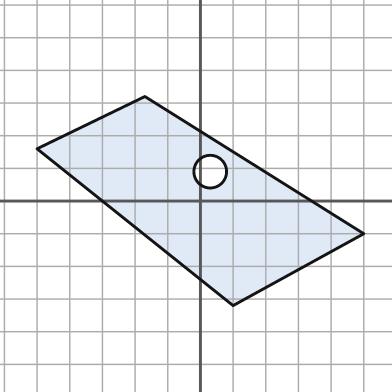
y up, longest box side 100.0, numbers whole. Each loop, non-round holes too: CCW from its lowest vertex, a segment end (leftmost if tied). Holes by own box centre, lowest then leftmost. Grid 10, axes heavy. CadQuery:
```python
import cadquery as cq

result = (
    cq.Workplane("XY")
    .moveTo(10.0, -32.0)
    .lineTo(50.0, -10.0)
    .lineTo(-17.0, 32.0)
    .lineTo(-50.0, 16.0)
    .close()
    .moveTo(3.0, 9.0)
    .circle(5.0)
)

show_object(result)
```